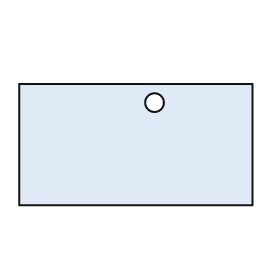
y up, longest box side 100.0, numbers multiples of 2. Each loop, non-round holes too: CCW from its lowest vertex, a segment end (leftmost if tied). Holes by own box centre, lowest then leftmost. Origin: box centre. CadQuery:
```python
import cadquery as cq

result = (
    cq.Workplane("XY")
    .moveTo(-50.0, -26.0)
    .lineTo(50.0, -26.0)
    .lineTo(50.0, 26.0)
    .lineTo(-50.0, 26.0)
    .close()
    .moveTo(8.0, 18.0)
    .circle(4.0)
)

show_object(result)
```